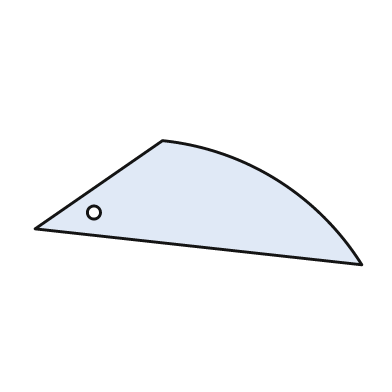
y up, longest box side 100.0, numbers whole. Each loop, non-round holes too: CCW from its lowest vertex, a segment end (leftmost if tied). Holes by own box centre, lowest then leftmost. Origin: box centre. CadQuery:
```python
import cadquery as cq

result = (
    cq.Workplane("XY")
    .moveTo(50.0, -19.0)
    .threePointArc((24.0, 7.0), (-11.0, 19.0))
    .lineTo(-50.0, -8.0)
    .close()
    .moveTo(-32.0, -3.0)
    .circle(2.0)
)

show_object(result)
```